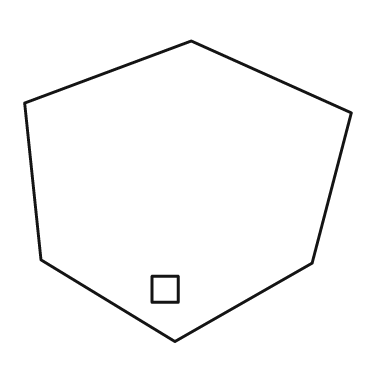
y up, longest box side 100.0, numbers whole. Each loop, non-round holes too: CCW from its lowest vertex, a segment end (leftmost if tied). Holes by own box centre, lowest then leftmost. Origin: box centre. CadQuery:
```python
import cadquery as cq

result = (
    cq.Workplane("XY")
    .moveTo(-4.0, -46.0)
    .lineTo(38.0, -22.0)
    .lineTo(50.0, 24.0)
    .lineTo(1.0, 46.0)
    .lineTo(-50.0, 27.0)
    .lineTo(-45.0, -21.0)
    .close()
    .moveTo(-11.0, -34.0)
    .lineTo(-3.0, -34.0)
    .lineTo(-3.0, -26.0)
    .lineTo(-11.0, -26.0)
    .close()
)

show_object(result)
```